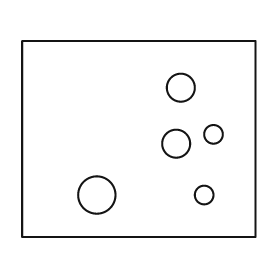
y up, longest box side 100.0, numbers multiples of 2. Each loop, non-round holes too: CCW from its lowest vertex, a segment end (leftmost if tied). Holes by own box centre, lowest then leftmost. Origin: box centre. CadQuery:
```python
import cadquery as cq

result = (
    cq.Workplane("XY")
    .moveTo(-50.0, -42.0)
    .lineTo(50.0, -42.0)
    .lineTo(50.0, 42.0)
    .lineTo(-50.0, 42.0)
    .close()
    .moveTo(-18.0, -24.0)
    .circle(8.0)
    .moveTo(28.0, -24.0)
    .circle(4.0)
    .moveTo(16.0, -2.0)
    .circle(6.0)
    .moveTo(32.0, 2.0)
    .circle(4.0)
    .moveTo(18.0, 22.0)
    .circle(6.0)
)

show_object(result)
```